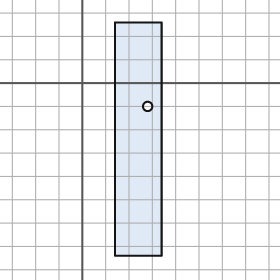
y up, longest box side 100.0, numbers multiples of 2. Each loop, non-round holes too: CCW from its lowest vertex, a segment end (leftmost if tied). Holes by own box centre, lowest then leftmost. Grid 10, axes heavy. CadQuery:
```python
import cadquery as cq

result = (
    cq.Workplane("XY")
    .moveTo(14.0, -74.0)
    .lineTo(34.0, -74.0)
    .lineTo(34.0, 26.0)
    .lineTo(14.0, 26.0)
    .close()
    .moveTo(28.0, -10.0)
    .circle(2.0)
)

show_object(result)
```